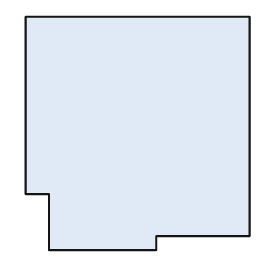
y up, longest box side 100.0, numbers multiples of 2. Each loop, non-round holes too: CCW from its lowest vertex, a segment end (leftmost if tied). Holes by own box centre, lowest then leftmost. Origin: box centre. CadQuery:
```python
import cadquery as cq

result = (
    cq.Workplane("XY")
    .moveTo(-38.0, -50.0)
    .lineTo(8.0, -50.0)
    .lineTo(8.0, -44.0)
    .lineTo(48.0, -44.0)
    .lineTo(48.0, 50.0)
    .lineTo(-48.0, 50.0)
    .lineTo(-48.0, -26.0)
    .lineTo(-38.0, -26.0)
    .close()
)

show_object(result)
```